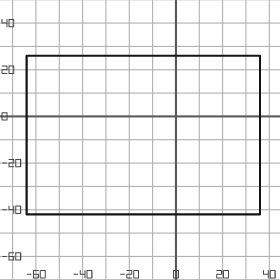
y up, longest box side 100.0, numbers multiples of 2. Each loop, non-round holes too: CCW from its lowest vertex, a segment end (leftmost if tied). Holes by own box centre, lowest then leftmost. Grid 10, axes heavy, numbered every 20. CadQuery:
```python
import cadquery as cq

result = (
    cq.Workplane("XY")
    .moveTo(-64.0, -42.0)
    .lineTo(36.0, -42.0)
    .lineTo(36.0, 26.0)
    .lineTo(-64.0, 26.0)
    .close()
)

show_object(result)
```